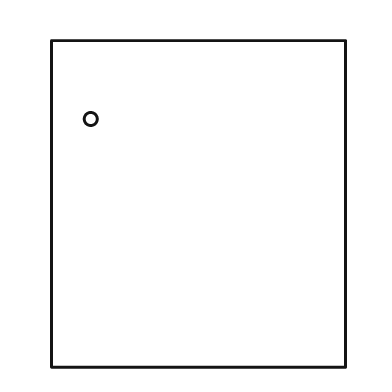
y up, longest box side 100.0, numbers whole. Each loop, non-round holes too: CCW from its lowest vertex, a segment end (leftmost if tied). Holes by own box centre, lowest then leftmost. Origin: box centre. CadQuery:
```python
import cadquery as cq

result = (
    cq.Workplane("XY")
    .moveTo(-45.0, -50.0)
    .lineTo(45.0, -50.0)
    .lineTo(45.0, 50.0)
    .lineTo(-45.0, 50.0)
    .close()
    .moveTo(-33.0, 26.0)
    .circle(2.0)
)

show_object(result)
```